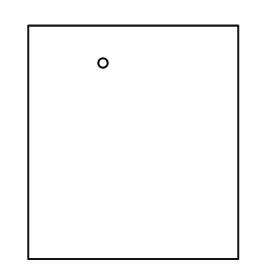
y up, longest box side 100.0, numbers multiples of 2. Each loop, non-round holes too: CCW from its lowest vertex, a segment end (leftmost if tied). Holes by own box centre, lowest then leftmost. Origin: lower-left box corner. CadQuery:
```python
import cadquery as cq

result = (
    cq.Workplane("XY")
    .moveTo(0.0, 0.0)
    .lineTo(90.0, 0.0)
    .lineTo(90.0, 100.0)
    .lineTo(0.0, 100.0)
    .close()
    .moveTo(32.0, 84.0)
    .circle(2.0)
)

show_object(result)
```